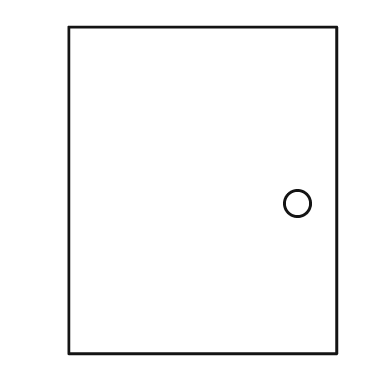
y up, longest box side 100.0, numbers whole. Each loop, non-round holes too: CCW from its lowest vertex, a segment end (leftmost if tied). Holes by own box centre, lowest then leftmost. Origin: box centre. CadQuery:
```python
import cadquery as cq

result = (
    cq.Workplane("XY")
    .moveTo(-41.0, -50.0)
    .lineTo(41.0, -50.0)
    .lineTo(41.0, 50.0)
    .lineTo(-41.0, 50.0)
    .close()
    .moveTo(29.0, -4.0)
    .circle(4.0)
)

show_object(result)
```